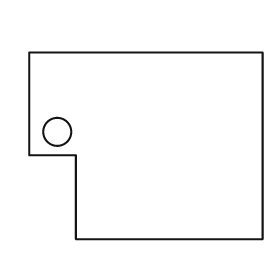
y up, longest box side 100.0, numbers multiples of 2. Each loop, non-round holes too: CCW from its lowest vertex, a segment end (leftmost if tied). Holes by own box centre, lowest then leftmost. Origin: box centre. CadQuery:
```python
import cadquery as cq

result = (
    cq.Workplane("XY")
    .moveTo(-30.0, -40.0)
    .lineTo(50.0, -40.0)
    .lineTo(50.0, 40.0)
    .lineTo(-50.0, 40.0)
    .lineTo(-50.0, -4.0)
    .lineTo(-30.0, -4.0)
    .close()
    .moveTo(-38.0, 6.0)
    .circle(6.0)
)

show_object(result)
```